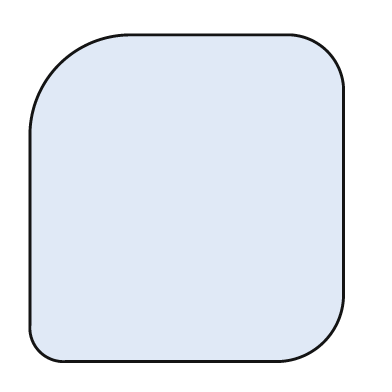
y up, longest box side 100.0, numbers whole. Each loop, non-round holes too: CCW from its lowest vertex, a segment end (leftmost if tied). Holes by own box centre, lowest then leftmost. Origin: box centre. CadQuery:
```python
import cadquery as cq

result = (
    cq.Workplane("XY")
    .moveTo(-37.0, -50.0)
    .lineTo(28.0, -50.0)
    .threePointArc((42.0, -44.0), (48.0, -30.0))
    .lineTo(48.0, 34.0)
    .threePointArc((43.0, 45.0), (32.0, 50.0))
    .lineTo(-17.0, 50.0)
    .threePointArc((-39.0, 41.0), (-48.0, 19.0))
    .lineTo(-48.0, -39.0)
    .threePointArc((-45.0, -47.0), (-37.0, -50.0))
    .close()
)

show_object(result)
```